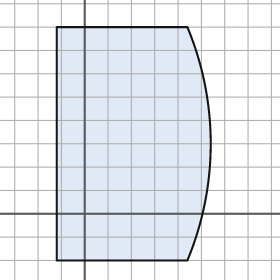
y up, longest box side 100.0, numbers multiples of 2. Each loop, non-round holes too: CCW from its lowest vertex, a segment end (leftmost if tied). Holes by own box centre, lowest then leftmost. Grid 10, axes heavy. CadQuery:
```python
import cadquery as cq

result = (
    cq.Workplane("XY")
    .moveTo(-12.0, -20.0)
    .lineTo(44.0, -20.0)
    .threePointArc((54.0, 30.0), (44.0, 80.0))
    .lineTo(-12.0, 80.0)
    .close()
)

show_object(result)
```